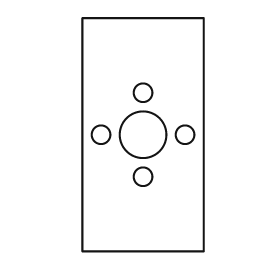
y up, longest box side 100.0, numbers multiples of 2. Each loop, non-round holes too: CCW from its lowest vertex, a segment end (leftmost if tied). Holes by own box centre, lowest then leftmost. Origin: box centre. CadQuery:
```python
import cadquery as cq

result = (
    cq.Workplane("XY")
    .moveTo(-26.0, -50.0)
    .lineTo(26.0, -50.0)
    .lineTo(26.0, 50.0)
    .lineTo(-26.0, 50.0)
    .close()
    .moveTo(0.0, -18.0)
    .circle(4.0)
    .moveTo(-18.0, 0.0)
    .circle(4.0)
    .moveTo(0.0, 0.0)
    .circle(10.0)
    .moveTo(18.0, 0.0)
    .circle(4.0)
    .moveTo(0.0, 18.0)
    .circle(4.0)
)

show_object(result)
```